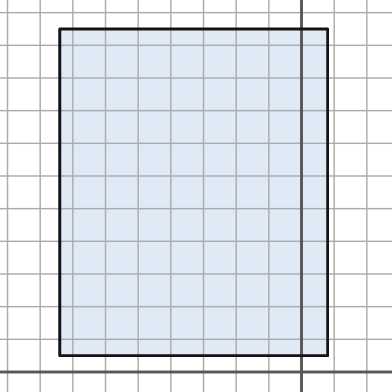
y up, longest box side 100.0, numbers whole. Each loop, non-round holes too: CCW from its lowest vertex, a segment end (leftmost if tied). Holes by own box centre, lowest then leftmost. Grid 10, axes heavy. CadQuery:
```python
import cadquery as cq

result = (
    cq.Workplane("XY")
    .moveTo(-74.0, 5.0)
    .lineTo(8.0, 5.0)
    .lineTo(8.0, 105.0)
    .lineTo(-74.0, 105.0)
    .close()
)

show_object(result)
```